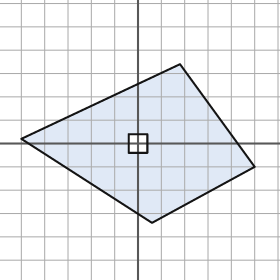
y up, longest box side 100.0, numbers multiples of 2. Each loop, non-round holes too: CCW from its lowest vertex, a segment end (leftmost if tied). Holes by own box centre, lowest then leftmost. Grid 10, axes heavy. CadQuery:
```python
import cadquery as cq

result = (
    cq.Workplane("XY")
    .moveTo(6.0, -34.0)
    .lineTo(50.0, -10.0)
    .lineTo(18.0, 34.0)
    .lineTo(-50.0, 2.0)
    .close()
    .moveTo(-4.0, -4.0)
    .lineTo(4.0, -4.0)
    .lineTo(4.0, 4.0)
    .lineTo(-4.0, 4.0)
    .close()
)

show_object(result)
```